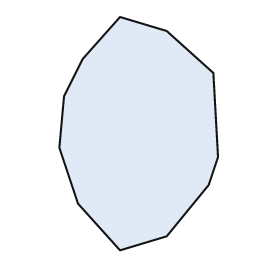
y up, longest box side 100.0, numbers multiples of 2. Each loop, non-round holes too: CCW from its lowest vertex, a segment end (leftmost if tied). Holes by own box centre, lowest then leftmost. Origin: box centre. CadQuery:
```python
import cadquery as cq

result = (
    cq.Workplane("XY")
    .moveTo(-8.0, -50.0)
    .lineTo(12.0, -44.0)
    .lineTo(30.0, -22.0)
    .lineTo(34.0, -10.0)
    .lineTo(32.0, 26.0)
    .lineTo(12.0, 44.0)
    .lineTo(-8.0, 50.0)
    .lineTo(-24.0, 32.0)
    .lineTo(-32.0, 16.0)
    .lineTo(-34.0, -6.0)
    .lineTo(-26.0, -30.0)
    .close()
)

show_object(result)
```